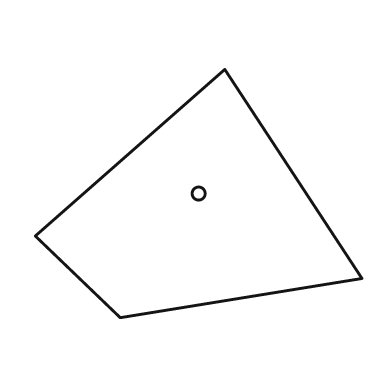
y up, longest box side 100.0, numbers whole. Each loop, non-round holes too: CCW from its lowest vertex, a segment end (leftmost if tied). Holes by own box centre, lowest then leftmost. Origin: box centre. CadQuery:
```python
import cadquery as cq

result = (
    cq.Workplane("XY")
    .moveTo(-24.0, -38.0)
    .lineTo(50.0, -26.0)
    .lineTo(8.0, 38.0)
    .lineTo(-50.0, -13.0)
    .close()
    .moveTo(0.0, 0.0)
    .circle(2.0)
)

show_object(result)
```